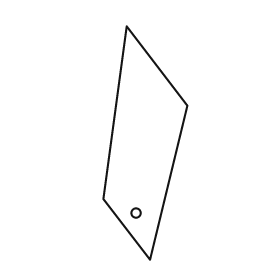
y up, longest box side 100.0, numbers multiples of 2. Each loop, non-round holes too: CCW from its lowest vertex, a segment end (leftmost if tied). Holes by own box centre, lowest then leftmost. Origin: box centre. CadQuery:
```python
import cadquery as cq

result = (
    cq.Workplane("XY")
    .moveTo(2.0, -50.0)
    .lineTo(18.0, 16.0)
    .lineTo(-8.0, 50.0)
    .lineTo(-18.0, -24.0)
    .close()
    .moveTo(-4.0, -30.0)
    .circle(2.0)
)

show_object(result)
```